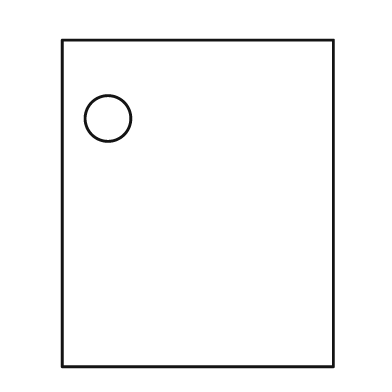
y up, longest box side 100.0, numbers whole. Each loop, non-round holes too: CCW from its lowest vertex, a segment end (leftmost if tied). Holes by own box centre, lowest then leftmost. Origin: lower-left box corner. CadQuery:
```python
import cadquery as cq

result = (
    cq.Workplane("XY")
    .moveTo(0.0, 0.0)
    .lineTo(83.0, 0.0)
    .lineTo(83.0, 100.0)
    .lineTo(0.0, 100.0)
    .close()
    .moveTo(14.0, 76.0)
    .circle(7.0)
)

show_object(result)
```